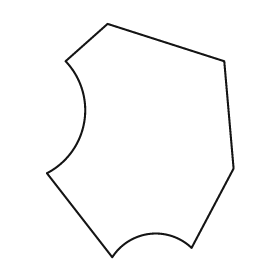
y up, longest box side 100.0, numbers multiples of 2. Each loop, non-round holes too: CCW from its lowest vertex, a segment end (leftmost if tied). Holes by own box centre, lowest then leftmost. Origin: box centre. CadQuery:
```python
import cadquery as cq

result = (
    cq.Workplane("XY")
    .moveTo(-12.0, -50.0)
    .threePointArc((4.0, -40.0), (22.0, -46.0))
    .lineTo(40.0, -12.0)
    .lineTo(36.0, 34.0)
    .lineTo(-14.0, 50.0)
    .lineTo(-32.0, 34.0)
    .threePointArc((-24.0, 8.0), (-40.0, -14.0))
    .close()
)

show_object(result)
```